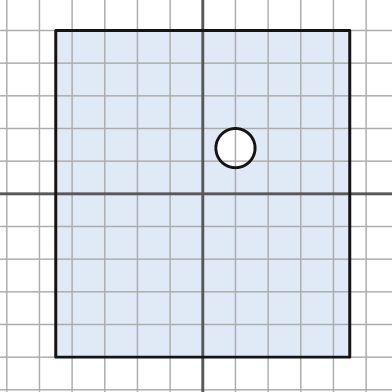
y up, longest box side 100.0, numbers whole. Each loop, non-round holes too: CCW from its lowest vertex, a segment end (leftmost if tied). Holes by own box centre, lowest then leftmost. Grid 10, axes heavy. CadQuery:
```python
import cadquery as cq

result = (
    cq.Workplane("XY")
    .moveTo(-45.0, -50.0)
    .lineTo(45.0, -50.0)
    .lineTo(45.0, 50.0)
    .lineTo(-45.0, 50.0)
    .close()
    .moveTo(10.0, 14.0)
    .circle(6.0)
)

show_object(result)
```